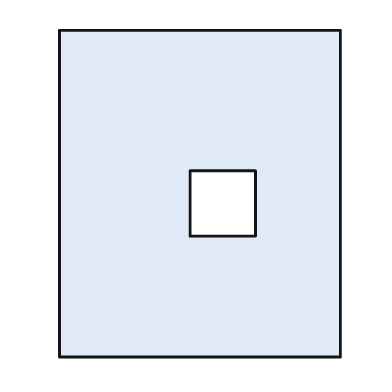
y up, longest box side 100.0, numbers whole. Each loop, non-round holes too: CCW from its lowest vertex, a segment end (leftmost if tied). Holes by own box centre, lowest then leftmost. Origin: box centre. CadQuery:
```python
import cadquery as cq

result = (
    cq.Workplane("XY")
    .moveTo(-43.0, -50.0)
    .lineTo(43.0, -50.0)
    .lineTo(43.0, 50.0)
    .lineTo(-43.0, 50.0)
    .close()
    .moveTo(-3.0, -13.0)
    .lineTo(17.0, -13.0)
    .lineTo(17.0, 7.0)
    .lineTo(-3.0, 7.0)
    .close()
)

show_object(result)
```